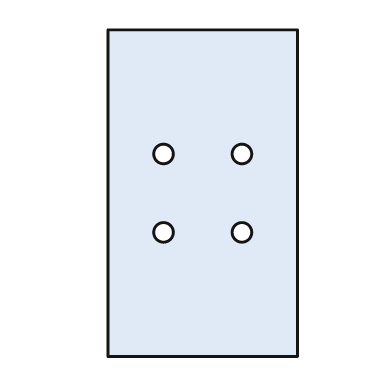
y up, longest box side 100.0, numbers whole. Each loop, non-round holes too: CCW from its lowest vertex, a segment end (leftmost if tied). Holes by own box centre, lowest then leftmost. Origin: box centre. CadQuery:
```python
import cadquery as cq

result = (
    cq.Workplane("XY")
    .moveTo(-29.0, -50.0)
    .lineTo(29.0, -50.0)
    .lineTo(29.0, 50.0)
    .lineTo(-29.0, 50.0)
    .close()
    .moveTo(-12.0, -12.0)
    .circle(3.0)
    .moveTo(12.0, -12.0)
    .circle(3.0)
    .moveTo(-12.0, 12.0)
    .circle(3.0)
    .moveTo(12.0, 12.0)
    .circle(3.0)
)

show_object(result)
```